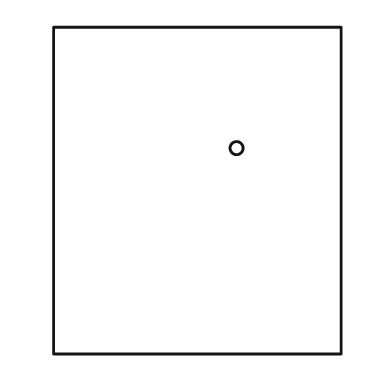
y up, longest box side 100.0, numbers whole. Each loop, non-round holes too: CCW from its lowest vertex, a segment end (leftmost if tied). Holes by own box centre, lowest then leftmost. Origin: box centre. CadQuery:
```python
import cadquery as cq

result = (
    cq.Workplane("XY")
    .moveTo(-44.0, -50.0)
    .lineTo(44.0, -50.0)
    .lineTo(44.0, 50.0)
    .lineTo(-44.0, 50.0)
    .close()
    .moveTo(12.0, 13.0)
    .circle(2.0)
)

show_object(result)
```